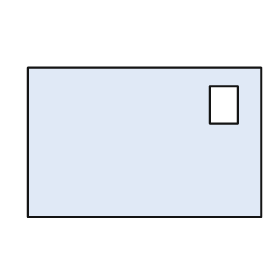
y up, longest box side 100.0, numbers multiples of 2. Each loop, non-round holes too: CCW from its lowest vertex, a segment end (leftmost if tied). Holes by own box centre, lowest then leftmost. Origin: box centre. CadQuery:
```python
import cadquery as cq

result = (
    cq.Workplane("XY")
    .moveTo(-50.0, -32.0)
    .lineTo(50.0, -32.0)
    .lineTo(50.0, 32.0)
    .lineTo(-50.0, 32.0)
    .close()
    .moveTo(28.0, 8.0)
    .lineTo(40.0, 8.0)
    .lineTo(40.0, 24.0)
    .lineTo(28.0, 24.0)
    .close()
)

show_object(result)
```